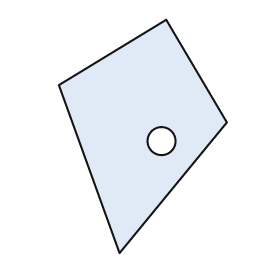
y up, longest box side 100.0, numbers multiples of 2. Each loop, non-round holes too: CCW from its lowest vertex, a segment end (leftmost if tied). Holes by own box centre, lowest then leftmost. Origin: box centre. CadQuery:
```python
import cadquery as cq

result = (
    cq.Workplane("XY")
    .moveTo(-10.0, -50.0)
    .lineTo(36.0, 6.0)
    .lineTo(10.0, 50.0)
    .lineTo(-36.0, 22.0)
    .close()
    .moveTo(8.0, -2.0)
    .circle(6.0)
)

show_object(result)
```